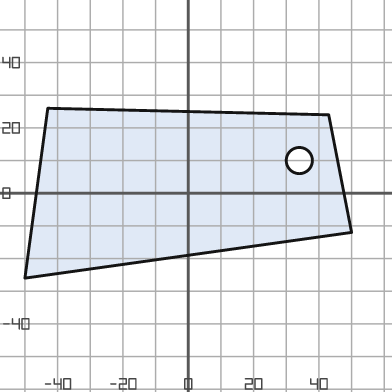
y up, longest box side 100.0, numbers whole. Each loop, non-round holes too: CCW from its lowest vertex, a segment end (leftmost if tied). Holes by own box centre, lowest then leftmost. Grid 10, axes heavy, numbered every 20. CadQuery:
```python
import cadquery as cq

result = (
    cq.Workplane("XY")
    .moveTo(-50.0, -26.0)
    .lineTo(50.0, -12.0)
    .lineTo(43.0, 24.0)
    .lineTo(-43.0, 26.0)
    .close()
    .moveTo(34.0, 10.0)
    .circle(4.0)
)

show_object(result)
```